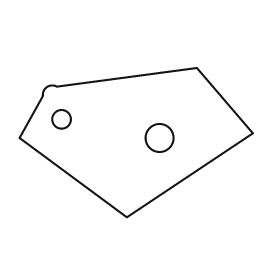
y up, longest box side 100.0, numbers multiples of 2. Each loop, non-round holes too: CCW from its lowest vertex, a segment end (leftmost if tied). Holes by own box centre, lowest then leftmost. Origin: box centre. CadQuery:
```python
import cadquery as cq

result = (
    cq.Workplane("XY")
    .moveTo(-4.0, -32.0)
    .lineTo(50.0, 4.0)
    .lineTo(26.0, 32.0)
    .lineTo(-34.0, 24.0)
    .threePointArc((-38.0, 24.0), (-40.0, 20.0))
    .lineTo(-50.0, 2.0)
    .close()
    .moveTo(10.0, 2.0)
    .circle(6.0)
    .moveTo(-32.0, 10.0)
    .circle(4.0)
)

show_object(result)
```